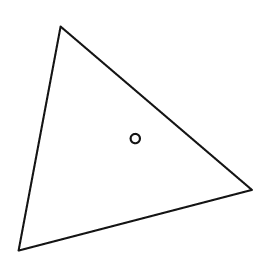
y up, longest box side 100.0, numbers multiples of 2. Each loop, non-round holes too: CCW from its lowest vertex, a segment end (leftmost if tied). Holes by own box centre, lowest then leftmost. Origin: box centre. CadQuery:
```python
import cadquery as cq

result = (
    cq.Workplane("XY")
    .moveTo(-50.0, -48.0)
    .lineTo(50.0, -22.0)
    .lineTo(-32.0, 48.0)
    .close()
    .moveTo(0.0, 0.0)
    .circle(2.0)
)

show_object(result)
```